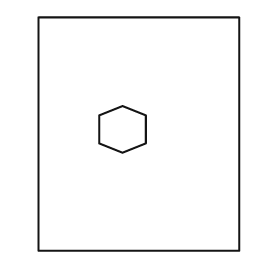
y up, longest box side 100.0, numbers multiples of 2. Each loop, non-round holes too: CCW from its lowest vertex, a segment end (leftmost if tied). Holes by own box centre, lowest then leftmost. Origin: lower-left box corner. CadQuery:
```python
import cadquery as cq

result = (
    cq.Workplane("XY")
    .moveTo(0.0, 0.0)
    .lineTo(86.0, 0.0)
    .lineTo(86.0, 100.0)
    .lineTo(0.0, 100.0)
    .close()
    .moveTo(36.0, 42.0)
    .lineTo(46.0, 46.0)
    .lineTo(46.0, 58.0)
    .lineTo(36.0, 62.0)
    .lineTo(26.0, 58.0)
    .lineTo(26.0, 46.0)
    .close()
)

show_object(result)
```